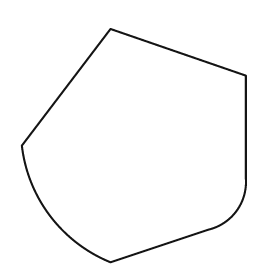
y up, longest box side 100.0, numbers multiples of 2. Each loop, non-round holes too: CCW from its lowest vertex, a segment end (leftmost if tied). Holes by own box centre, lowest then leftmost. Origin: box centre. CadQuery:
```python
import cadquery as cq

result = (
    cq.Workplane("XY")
    .moveTo(-10.0, -50.0)
    .lineTo(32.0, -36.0)
    .threePointArc((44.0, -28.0), (48.0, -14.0))
    .lineTo(48.0, 30.0)
    .lineTo(-10.0, 50.0)
    .lineTo(-48.0, 0.0)
    .threePointArc((-36.0, -30.0), (-10.0, -50.0))
    .close()
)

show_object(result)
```